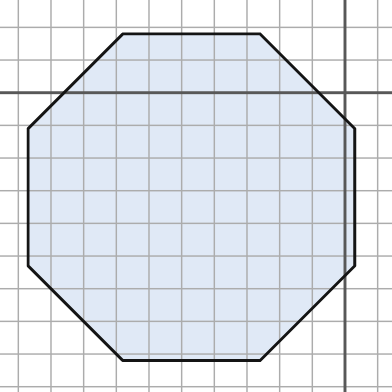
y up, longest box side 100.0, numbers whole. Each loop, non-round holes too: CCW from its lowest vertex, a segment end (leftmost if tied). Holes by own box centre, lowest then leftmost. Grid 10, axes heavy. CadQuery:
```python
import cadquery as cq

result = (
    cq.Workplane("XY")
    .moveTo(-68.0, -82.0)
    .lineTo(-26.0, -82.0)
    .lineTo(3.0, -53.0)
    .lineTo(3.0, -11.0)
    .lineTo(-26.0, 18.0)
    .lineTo(-68.0, 18.0)
    .lineTo(-97.0, -11.0)
    .lineTo(-97.0, -53.0)
    .close()
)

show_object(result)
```